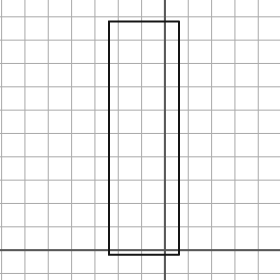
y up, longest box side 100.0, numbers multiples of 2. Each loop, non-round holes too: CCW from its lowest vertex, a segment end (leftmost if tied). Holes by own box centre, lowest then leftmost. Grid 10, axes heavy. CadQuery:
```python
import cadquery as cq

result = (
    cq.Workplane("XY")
    .moveTo(-24.0, -2.0)
    .lineTo(6.0, -2.0)
    .lineTo(6.0, 98.0)
    .lineTo(-24.0, 98.0)
    .close()
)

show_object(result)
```